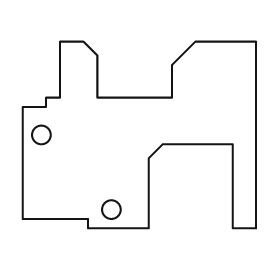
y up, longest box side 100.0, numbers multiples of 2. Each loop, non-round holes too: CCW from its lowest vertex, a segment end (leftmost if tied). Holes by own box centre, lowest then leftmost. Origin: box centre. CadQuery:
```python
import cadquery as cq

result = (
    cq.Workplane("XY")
    .moveTo(-22.0, -40.0)
    .lineTo(4.0, -40.0)
    .lineTo(4.0, -10.0)
    .lineTo(10.0, -4.0)
    .lineTo(40.0, -4.0)
    .lineTo(40.0, -40.0)
    .lineTo(50.0, -40.0)
    .lineTo(50.0, 40.0)
    .lineTo(24.0, 40.0)
    .lineTo(14.0, 30.0)
    .lineTo(14.0, 16.0)
    .lineTo(-18.0, 16.0)
    .lineTo(-18.0, 34.0)
    .lineTo(-24.0, 40.0)
    .lineTo(-34.0, 40.0)
    .lineTo(-34.0, 16.0)
    .lineTo(-40.0, 16.0)
    .lineTo(-40.0, 12.0)
    .lineTo(-50.0, 12.0)
    .lineTo(-50.0, -36.0)
    .lineTo(-22.0, -36.0)
    .close()
    .moveTo(-12.0, -32.0)
    .circle(4.0)
    .moveTo(-42.0, 0.0)
    .circle(4.0)
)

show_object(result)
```